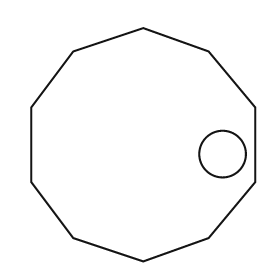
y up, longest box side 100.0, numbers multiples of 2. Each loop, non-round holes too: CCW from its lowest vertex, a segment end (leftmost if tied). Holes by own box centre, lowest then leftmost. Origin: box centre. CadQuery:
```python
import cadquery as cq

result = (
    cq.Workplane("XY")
    .moveTo(0.0, -50.0)
    .lineTo(28.0, -40.0)
    .lineTo(48.0, -16.0)
    .lineTo(48.0, 16.0)
    .lineTo(28.0, 40.0)
    .lineTo(0.0, 50.0)
    .lineTo(-30.0, 40.0)
    .lineTo(-48.0, 16.0)
    .lineTo(-48.0, -16.0)
    .lineTo(-30.0, -40.0)
    .close()
    .moveTo(34.0, -4.0)
    .circle(10.0)
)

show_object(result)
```